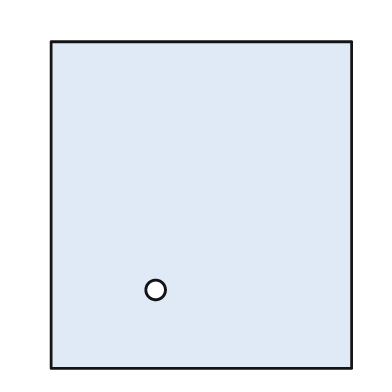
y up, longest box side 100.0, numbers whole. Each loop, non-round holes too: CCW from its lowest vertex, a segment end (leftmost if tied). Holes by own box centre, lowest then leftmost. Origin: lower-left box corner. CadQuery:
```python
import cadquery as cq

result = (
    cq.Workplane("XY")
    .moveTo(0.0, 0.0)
    .lineTo(92.0, 0.0)
    .lineTo(92.0, 100.0)
    .lineTo(0.0, 100.0)
    .close()
    .moveTo(32.0, 24.0)
    .circle(3.0)
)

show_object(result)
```